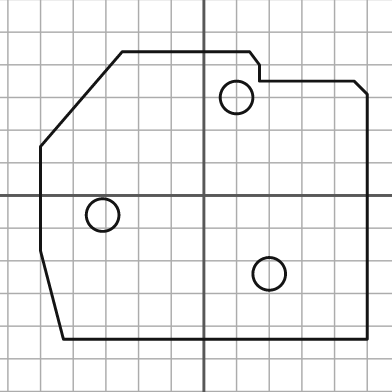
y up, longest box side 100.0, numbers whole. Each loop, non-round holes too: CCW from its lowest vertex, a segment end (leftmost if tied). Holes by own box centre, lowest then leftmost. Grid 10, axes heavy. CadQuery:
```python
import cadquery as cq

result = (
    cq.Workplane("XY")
    .moveTo(-43.0, -44.0)
    .lineTo(50.0, -44.0)
    .lineTo(50.0, 31.0)
    .lineTo(46.0, 35.0)
    .lineTo(17.0, 35.0)
    .lineTo(17.0, 40.0)
    .lineTo(14.0, 44.0)
    .lineTo(-25.0, 44.0)
    .lineTo(-50.0, 15.0)
    .lineTo(-50.0, -17.0)
    .close()
    .moveTo(20.0, -24.0)
    .circle(5.0)
    .moveTo(-31.0, -6.0)
    .circle(5.0)
    .moveTo(10.0, 30.0)
    .circle(5.0)
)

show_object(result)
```